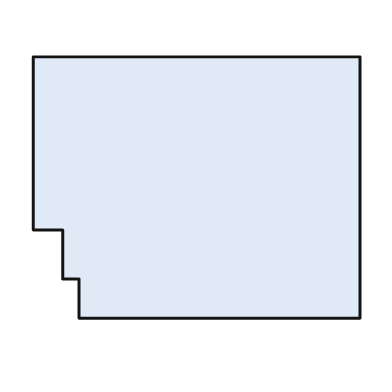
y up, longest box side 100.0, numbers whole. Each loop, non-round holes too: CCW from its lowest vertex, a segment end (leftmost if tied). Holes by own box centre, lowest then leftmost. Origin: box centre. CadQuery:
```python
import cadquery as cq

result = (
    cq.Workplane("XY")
    .moveTo(-36.0, -40.0)
    .lineTo(50.0, -40.0)
    .lineTo(50.0, 40.0)
    .lineTo(-50.0, 40.0)
    .lineTo(-50.0, -13.0)
    .lineTo(-41.0, -13.0)
    .lineTo(-41.0, -28.0)
    .lineTo(-36.0, -28.0)
    .close()
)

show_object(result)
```